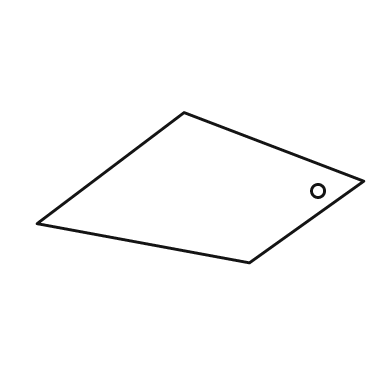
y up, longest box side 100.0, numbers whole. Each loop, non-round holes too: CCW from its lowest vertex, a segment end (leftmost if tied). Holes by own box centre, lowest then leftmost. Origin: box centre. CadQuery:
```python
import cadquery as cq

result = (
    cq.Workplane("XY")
    .moveTo(15.0, -23.0)
    .lineTo(50.0, 2.0)
    .lineTo(-5.0, 23.0)
    .lineTo(-50.0, -11.0)
    .close()
    .moveTo(36.0, -1.0)
    .circle(2.0)
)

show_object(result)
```